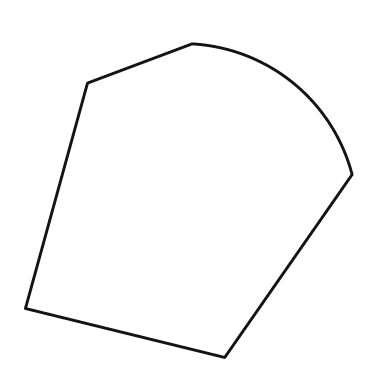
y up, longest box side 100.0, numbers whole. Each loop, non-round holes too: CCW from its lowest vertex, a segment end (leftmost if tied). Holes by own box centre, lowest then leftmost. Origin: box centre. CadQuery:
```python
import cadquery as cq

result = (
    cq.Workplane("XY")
    .moveTo(11.0, -48.0)
    .lineTo(50.0, 8.0)
    .threePointArc((32.0, 36.0), (1.0, 48.0))
    .lineTo(-31.0, 36.0)
    .lineTo(-50.0, -33.0)
    .close()
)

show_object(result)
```